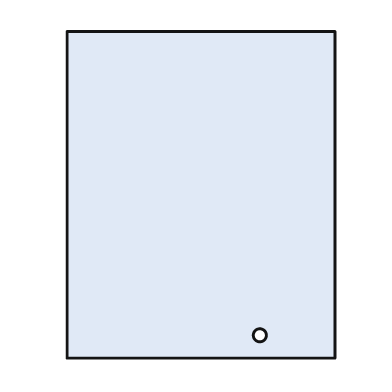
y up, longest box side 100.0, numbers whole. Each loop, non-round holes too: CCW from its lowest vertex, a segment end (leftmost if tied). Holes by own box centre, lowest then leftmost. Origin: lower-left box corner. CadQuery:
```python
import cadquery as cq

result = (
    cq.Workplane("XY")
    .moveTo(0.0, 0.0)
    .lineTo(82.0, 0.0)
    .lineTo(82.0, 100.0)
    .lineTo(0.0, 100.0)
    .close()
    .moveTo(59.0, 7.0)
    .circle(2.0)
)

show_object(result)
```